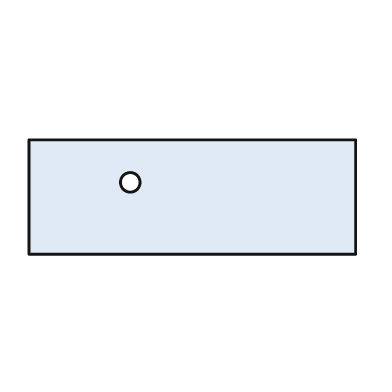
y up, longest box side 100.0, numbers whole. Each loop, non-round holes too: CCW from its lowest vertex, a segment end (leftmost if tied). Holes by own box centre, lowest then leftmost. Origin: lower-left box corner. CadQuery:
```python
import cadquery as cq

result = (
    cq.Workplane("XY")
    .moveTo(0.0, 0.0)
    .lineTo(100.0, 0.0)
    .lineTo(100.0, 35.0)
    .lineTo(0.0, 35.0)
    .close()
    .moveTo(31.0, 22.0)
    .circle(3.0)
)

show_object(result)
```